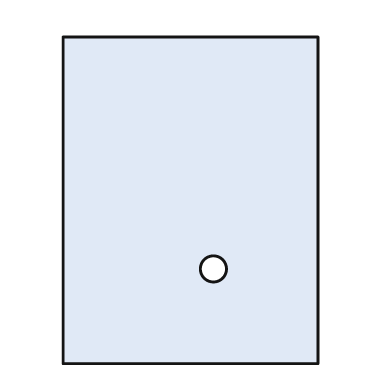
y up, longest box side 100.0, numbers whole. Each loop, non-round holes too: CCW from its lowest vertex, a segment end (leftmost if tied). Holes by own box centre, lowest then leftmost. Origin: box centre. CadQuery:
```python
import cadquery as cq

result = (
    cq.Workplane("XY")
    .moveTo(-39.0, -50.0)
    .lineTo(39.0, -50.0)
    .lineTo(39.0, 50.0)
    .lineTo(-39.0, 50.0)
    .close()
    .moveTo(7.0, -21.0)
    .circle(4.0)
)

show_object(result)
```